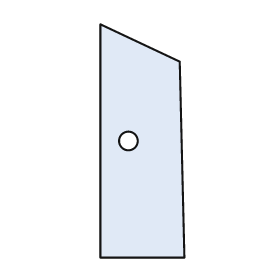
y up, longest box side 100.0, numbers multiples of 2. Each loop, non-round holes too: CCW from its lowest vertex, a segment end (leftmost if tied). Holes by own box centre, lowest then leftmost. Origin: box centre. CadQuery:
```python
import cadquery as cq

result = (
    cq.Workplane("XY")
    .moveTo(-18.0, -50.0)
    .lineTo(18.0, -50.0)
    .lineTo(16.0, 34.0)
    .lineTo(-18.0, 50.0)
    .close()
    .moveTo(-6.0, 0.0)
    .circle(4.0)
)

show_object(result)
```